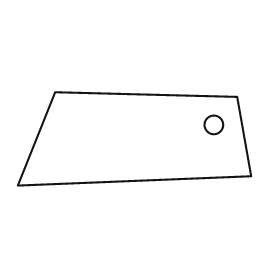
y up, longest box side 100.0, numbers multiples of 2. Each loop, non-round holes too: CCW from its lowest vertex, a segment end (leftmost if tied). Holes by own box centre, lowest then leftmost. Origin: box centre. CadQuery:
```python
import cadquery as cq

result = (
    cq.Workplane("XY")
    .moveTo(-50.0, -20.0)
    .lineTo(50.0, -16.0)
    .lineTo(44.0, 18.0)
    .lineTo(-34.0, 20.0)
    .close()
    .moveTo(34.0, 6.0)
    .circle(4.0)
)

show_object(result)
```